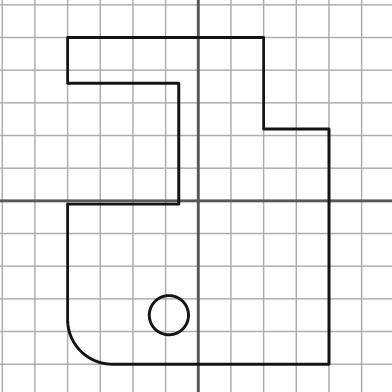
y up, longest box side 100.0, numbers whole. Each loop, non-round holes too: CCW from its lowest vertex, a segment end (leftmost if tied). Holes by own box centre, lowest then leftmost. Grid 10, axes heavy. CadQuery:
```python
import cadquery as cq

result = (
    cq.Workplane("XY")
    .moveTo(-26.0, -50.0)
    .lineTo(40.0, -50.0)
    .lineTo(40.0, 22.0)
    .lineTo(20.0, 22.0)
    .lineTo(20.0, 50.0)
    .lineTo(-40.0, 50.0)
    .lineTo(-40.0, 36.0)
    .lineTo(-6.0, 36.0)
    .lineTo(-6.0, -1.0)
    .lineTo(-40.0, -1.0)
    .lineTo(-40.0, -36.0)
    .threePointArc((-36.0, -46.0), (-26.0, -50.0))
    .close()
    .moveTo(-9.0, -35.0)
    .circle(6.0)
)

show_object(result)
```